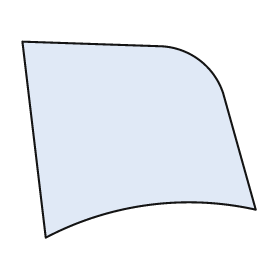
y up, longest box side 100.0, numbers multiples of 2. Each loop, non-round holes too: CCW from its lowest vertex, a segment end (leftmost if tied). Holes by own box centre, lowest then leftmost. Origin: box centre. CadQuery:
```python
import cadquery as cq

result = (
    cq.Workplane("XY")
    .moveTo(-40.0, -42.0)
    .threePointArc((4.0, -28.0), (50.0, -30.0))
    .lineTo(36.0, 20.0)
    .threePointArc((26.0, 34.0), (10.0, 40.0))
    .lineTo(-50.0, 42.0)
    .close()
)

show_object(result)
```